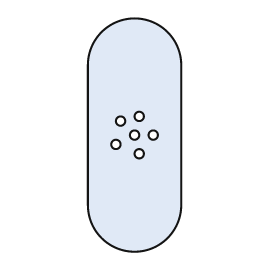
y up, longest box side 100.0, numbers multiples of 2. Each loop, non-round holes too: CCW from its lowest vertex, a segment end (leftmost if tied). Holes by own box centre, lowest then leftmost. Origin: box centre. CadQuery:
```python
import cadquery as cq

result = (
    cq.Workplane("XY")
    .moveTo(-20.0, -30.0)
    .threePointArc((0.0, -50.0), (20.0, -30.0))
    .lineTo(20.0, 30.0)
    .threePointArc((0.0, 50.0), (-20.0, 30.0))
    .close()
    .moveTo(2.0, -8.0)
    .circle(2.0)
    .moveTo(-8.0, -4.0)
    .circle(2.0)
    .moveTo(0.0, 0.0)
    .circle(2.0)
    .moveTo(8.0, 0.0)
    .circle(2.0)
    .moveTo(-6.0, 6.0)
    .circle(2.0)
    .moveTo(2.0, 8.0)
    .circle(2.0)
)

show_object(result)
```